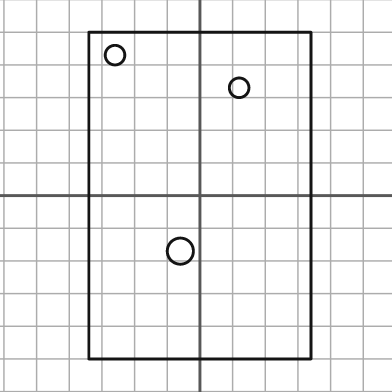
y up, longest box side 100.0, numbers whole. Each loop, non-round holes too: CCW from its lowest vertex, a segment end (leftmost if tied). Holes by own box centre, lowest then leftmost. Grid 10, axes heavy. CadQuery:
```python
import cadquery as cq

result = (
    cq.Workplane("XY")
    .moveTo(-34.0, -50.0)
    .lineTo(34.0, -50.0)
    .lineTo(34.0, 50.0)
    .lineTo(-34.0, 50.0)
    .close()
    .moveTo(-6.0, -17.0)
    .circle(4.0)
    .moveTo(12.0, 33.0)
    .circle(3.0)
    .moveTo(-26.0, 43.0)
    .circle(3.0)
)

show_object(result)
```